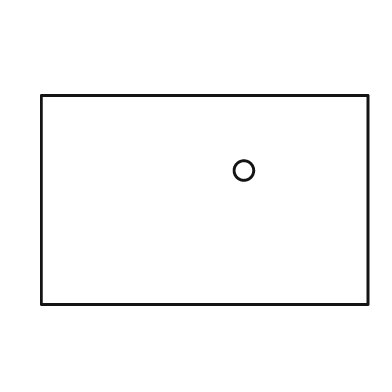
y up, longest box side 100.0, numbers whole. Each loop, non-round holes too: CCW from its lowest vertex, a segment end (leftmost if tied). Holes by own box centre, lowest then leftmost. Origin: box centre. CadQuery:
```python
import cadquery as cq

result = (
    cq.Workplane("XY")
    .moveTo(-50.0, -32.0)
    .lineTo(50.0, -32.0)
    .lineTo(50.0, 32.0)
    .lineTo(-50.0, 32.0)
    .close()
    .moveTo(12.0, 9.0)
    .circle(3.0)
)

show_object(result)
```